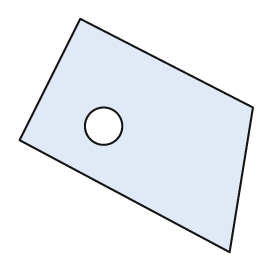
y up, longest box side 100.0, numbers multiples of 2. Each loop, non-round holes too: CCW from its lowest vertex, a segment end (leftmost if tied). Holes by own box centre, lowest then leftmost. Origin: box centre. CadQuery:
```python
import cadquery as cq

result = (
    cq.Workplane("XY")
    .moveTo(40.0, -50.0)
    .lineTo(50.0, 12.0)
    .lineTo(-24.0, 50.0)
    .lineTo(-50.0, -2.0)
    .close()
    .moveTo(-14.0, 4.0)
    .circle(8.0)
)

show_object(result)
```